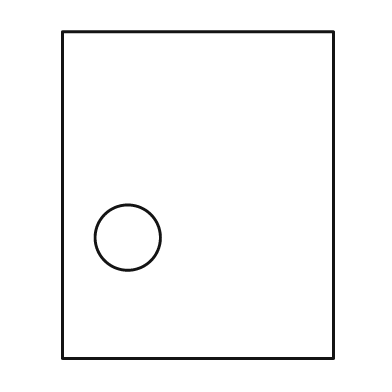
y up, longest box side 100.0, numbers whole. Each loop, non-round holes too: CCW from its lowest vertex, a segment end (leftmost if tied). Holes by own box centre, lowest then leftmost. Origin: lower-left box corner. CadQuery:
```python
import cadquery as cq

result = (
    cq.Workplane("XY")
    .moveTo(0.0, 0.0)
    .lineTo(83.0, 0.0)
    .lineTo(83.0, 100.0)
    .lineTo(0.0, 100.0)
    .close()
    .moveTo(20.0, 37.0)
    .circle(10.0)
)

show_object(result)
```